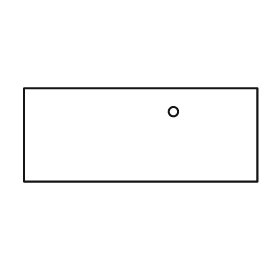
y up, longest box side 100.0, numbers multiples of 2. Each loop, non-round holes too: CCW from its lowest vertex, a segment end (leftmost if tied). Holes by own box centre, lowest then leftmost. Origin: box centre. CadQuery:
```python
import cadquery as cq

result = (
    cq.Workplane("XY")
    .moveTo(-50.0, -20.0)
    .lineTo(50.0, -20.0)
    .lineTo(50.0, 20.0)
    .lineTo(-50.0, 20.0)
    .close()
    .moveTo(14.0, 10.0)
    .circle(2.0)
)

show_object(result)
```